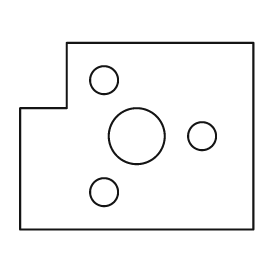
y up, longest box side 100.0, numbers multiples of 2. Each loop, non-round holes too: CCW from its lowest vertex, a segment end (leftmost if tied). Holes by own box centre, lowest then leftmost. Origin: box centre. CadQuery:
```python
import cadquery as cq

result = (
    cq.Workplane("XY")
    .moveTo(-50.0, -40.0)
    .lineTo(50.0, -40.0)
    .lineTo(50.0, 40.0)
    .lineTo(-30.0, 40.0)
    .lineTo(-30.0, 12.0)
    .lineTo(-50.0, 12.0)
    .close()
    .moveTo(-14.0, -24.0)
    .circle(6.0)
    .moveTo(0.0, 0.0)
    .circle(12.0)
    .moveTo(28.0, 0.0)
    .circle(6.0)
    .moveTo(-14.0, 24.0)
    .circle(6.0)
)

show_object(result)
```